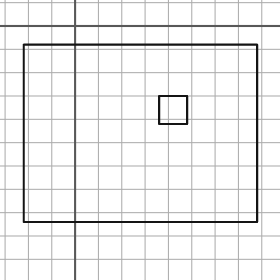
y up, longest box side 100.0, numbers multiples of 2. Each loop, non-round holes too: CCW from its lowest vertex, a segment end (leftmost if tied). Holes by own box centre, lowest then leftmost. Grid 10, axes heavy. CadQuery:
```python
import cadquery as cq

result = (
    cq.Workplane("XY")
    .moveTo(-22.0, -84.0)
    .lineTo(78.0, -84.0)
    .lineTo(78.0, -8.0)
    .lineTo(-22.0, -8.0)
    .close()
    .moveTo(36.0, -42.0)
    .lineTo(48.0, -42.0)
    .lineTo(48.0, -30.0)
    .lineTo(36.0, -30.0)
    .close()
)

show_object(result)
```